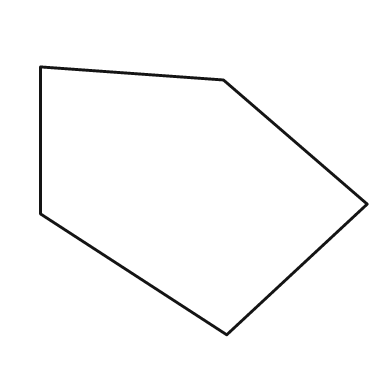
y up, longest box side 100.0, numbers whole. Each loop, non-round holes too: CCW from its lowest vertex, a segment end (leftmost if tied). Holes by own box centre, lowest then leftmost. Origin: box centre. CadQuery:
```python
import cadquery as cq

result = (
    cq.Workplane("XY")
    .moveTo(7.0, -41.0)
    .lineTo(50.0, -1.0)
    .lineTo(6.0, 37.0)
    .lineTo(-50.0, 41.0)
    .lineTo(-50.0, -4.0)
    .close()
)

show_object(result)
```